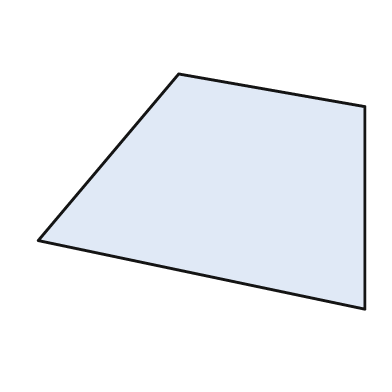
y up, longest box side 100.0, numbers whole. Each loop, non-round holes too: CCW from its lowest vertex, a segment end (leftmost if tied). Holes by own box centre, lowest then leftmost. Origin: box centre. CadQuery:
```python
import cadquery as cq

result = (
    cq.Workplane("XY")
    .moveTo(50.0, -36.0)
    .lineTo(50.0, 26.0)
    .lineTo(-7.0, 36.0)
    .lineTo(-50.0, -15.0)
    .close()
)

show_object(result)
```